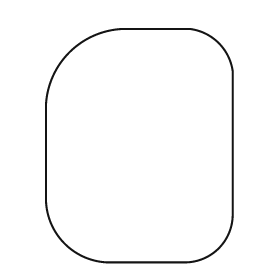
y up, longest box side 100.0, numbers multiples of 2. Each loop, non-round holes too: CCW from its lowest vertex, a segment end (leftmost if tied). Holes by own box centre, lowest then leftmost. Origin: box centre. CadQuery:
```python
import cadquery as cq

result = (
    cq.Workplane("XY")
    .moveTo(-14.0, -50.0)
    .lineTo(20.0, -50.0)
    .threePointArc((34.0, -44.0), (40.0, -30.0))
    .lineTo(40.0, 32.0)
    .threePointArc((34.0, 44.0), (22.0, 50.0))
    .lineTo(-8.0, 50.0)
    .threePointArc((-30.0, 40.0), (-40.0, 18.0))
    .lineTo(-40.0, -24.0)
    .threePointArc((-32.0, -42.0), (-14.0, -50.0))
    .close()
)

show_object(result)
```